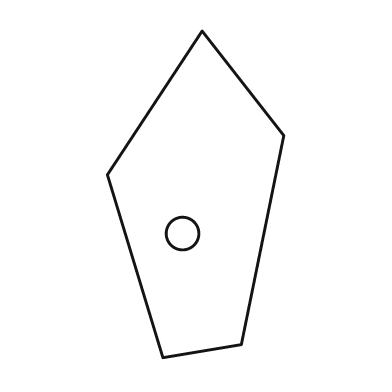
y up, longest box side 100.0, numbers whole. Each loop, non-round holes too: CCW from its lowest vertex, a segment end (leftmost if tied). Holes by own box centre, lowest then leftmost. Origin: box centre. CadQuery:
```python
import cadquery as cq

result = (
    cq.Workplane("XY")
    .moveTo(-10.0, -50.0)
    .lineTo(14.0, -46.0)
    .lineTo(27.0, 18.0)
    .lineTo(2.0, 50.0)
    .lineTo(-27.0, 6.0)
    .close()
    .moveTo(-4.0, -12.0)
    .circle(5.0)
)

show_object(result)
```